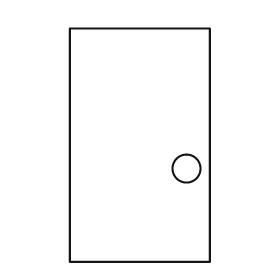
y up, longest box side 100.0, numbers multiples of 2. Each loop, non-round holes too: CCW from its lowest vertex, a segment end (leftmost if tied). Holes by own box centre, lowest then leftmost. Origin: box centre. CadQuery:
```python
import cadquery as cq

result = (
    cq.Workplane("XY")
    .moveTo(-30.0, -50.0)
    .lineTo(30.0, -50.0)
    .lineTo(30.0, 50.0)
    .lineTo(-30.0, 50.0)
    .close()
    .moveTo(20.0, -10.0)
    .circle(6.0)
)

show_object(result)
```